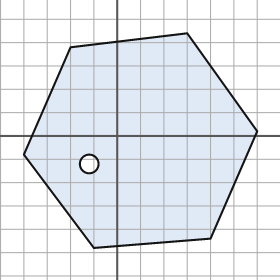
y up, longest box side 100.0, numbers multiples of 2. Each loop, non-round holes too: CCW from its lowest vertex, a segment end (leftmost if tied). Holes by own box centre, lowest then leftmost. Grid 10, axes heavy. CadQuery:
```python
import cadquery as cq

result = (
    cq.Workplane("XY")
    .moveTo(-10.0, -48.0)
    .lineTo(40.0, -44.0)
    .lineTo(60.0, 2.0)
    .lineTo(30.0, 44.0)
    .lineTo(-20.0, 38.0)
    .lineTo(-40.0, -8.0)
    .close()
    .moveTo(-12.0, -12.0)
    .circle(4.0)
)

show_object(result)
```